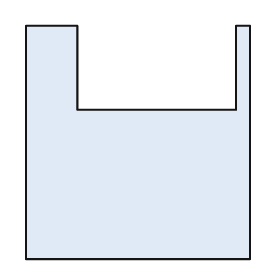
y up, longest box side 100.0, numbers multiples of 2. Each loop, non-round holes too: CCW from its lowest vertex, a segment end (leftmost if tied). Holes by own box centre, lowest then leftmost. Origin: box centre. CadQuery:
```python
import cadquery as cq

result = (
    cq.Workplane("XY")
    .moveTo(-48.0, -50.0)
    .lineTo(48.0, -50.0)
    .lineTo(48.0, 50.0)
    .lineTo(42.0, 50.0)
    .lineTo(42.0, 14.0)
    .lineTo(-26.0, 14.0)
    .lineTo(-26.0, 50.0)
    .lineTo(-48.0, 50.0)
    .close()
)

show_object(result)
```